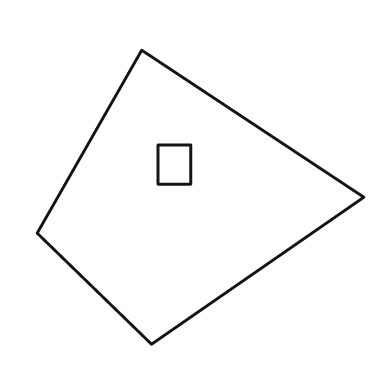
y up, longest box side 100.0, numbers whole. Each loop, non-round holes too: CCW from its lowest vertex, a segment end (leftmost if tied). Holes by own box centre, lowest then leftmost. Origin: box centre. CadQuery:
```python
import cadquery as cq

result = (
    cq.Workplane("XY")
    .moveTo(-15.0, -45.0)
    .lineTo(50.0, 0.0)
    .lineTo(-18.0, 45.0)
    .lineTo(-50.0, -11.0)
    .close()
    .moveTo(-13.0, 4.0)
    .lineTo(-3.0, 4.0)
    .lineTo(-3.0, 16.0)
    .lineTo(-13.0, 16.0)
    .close()
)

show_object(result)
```